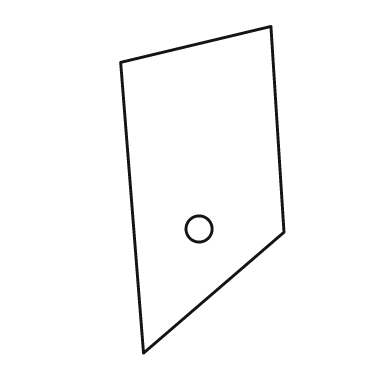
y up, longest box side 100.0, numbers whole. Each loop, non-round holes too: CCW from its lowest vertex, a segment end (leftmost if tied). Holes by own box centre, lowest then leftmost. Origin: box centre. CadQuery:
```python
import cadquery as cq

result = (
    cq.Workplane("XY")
    .moveTo(-18.0, -50.0)
    .lineTo(25.0, -13.0)
    .lineTo(21.0, 50.0)
    .lineTo(-25.0, 39.0)
    .close()
    .moveTo(-1.0, -12.0)
    .circle(4.0)
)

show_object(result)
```